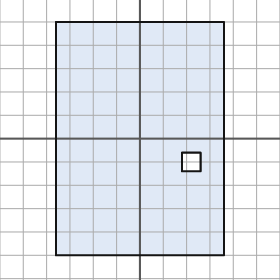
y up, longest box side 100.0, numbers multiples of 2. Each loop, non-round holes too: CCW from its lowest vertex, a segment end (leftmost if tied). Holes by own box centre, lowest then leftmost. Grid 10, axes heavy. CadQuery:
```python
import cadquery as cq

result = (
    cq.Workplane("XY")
    .moveTo(-36.0, -50.0)
    .lineTo(36.0, -50.0)
    .lineTo(36.0, 50.0)
    .lineTo(-36.0, 50.0)
    .close()
    .moveTo(18.0, -14.0)
    .lineTo(26.0, -14.0)
    .lineTo(26.0, -6.0)
    .lineTo(18.0, -6.0)
    .close()
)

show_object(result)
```